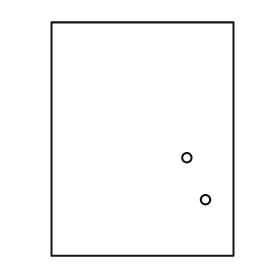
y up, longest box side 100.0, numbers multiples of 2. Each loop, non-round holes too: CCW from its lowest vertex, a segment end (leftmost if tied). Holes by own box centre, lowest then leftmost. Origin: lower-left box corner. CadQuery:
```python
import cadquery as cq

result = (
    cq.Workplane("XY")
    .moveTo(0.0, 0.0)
    .lineTo(78.0, 0.0)
    .lineTo(78.0, 100.0)
    .lineTo(0.0, 100.0)
    .close()
    .moveTo(66.0, 24.0)
    .circle(2.0)
    .moveTo(58.0, 42.0)
    .circle(2.0)
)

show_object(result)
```